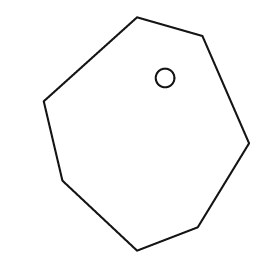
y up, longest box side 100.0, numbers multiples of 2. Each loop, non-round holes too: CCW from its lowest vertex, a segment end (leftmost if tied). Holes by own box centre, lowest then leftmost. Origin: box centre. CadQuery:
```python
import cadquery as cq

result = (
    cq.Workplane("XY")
    .moveTo(-4.0, -50.0)
    .lineTo(22.0, -40.0)
    .lineTo(44.0, -4.0)
    .lineTo(24.0, 42.0)
    .lineTo(-4.0, 50.0)
    .lineTo(-44.0, 14.0)
    .lineTo(-36.0, -20.0)
    .close()
    .moveTo(8.0, 24.0)
    .circle(4.0)
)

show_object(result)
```